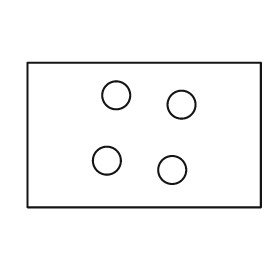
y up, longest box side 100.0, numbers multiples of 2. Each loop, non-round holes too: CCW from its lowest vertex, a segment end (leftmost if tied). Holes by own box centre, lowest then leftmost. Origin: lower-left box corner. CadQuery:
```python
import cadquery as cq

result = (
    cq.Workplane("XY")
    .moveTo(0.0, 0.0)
    .lineTo(100.0, 0.0)
    .lineTo(100.0, 62.0)
    .lineTo(0.0, 62.0)
    .close()
    .moveTo(62.0, 16.0)
    .circle(6.0)
    .moveTo(34.0, 20.0)
    .circle(6.0)
    .moveTo(66.0, 44.0)
    .circle(6.0)
    .moveTo(38.0, 48.0)
    .circle(6.0)
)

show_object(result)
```